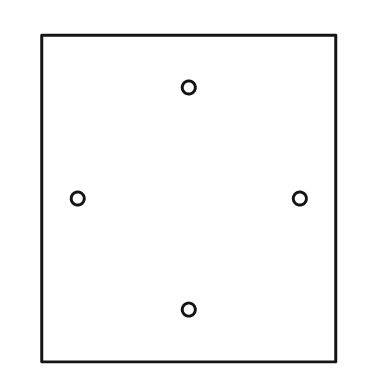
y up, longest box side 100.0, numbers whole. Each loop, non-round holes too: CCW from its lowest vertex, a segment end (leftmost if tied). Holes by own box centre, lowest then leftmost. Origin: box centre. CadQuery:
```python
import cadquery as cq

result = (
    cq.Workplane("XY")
    .moveTo(-45.0, -50.0)
    .lineTo(45.0, -50.0)
    .lineTo(45.0, 50.0)
    .lineTo(-45.0, 50.0)
    .close()
    .moveTo(0.0, -34.0)
    .circle(2.0)
    .moveTo(-34.0, 0.0)
    .circle(2.0)
    .moveTo(34.0, 0.0)
    .circle(2.0)
    .moveTo(0.0, 34.0)
    .circle(2.0)
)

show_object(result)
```